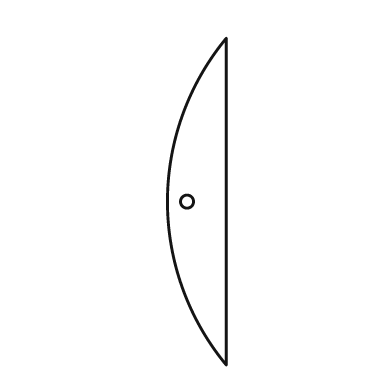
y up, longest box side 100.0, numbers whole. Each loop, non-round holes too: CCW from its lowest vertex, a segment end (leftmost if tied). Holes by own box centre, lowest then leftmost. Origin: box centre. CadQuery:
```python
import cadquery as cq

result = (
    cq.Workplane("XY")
    .moveTo(9.0, -50.0)
    .lineTo(9.0, 50.0)
    .threePointArc((-9.0, 0.0), (9.0, -50.0))
    .close()
    .moveTo(-3.0, 0.0)
    .circle(2.0)
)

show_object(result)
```